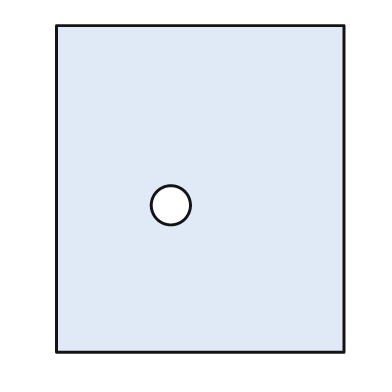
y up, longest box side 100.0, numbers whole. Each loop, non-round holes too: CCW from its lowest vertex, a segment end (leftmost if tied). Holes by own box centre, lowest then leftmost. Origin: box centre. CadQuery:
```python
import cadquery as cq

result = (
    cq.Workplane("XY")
    .moveTo(-44.0, -50.0)
    .lineTo(44.0, -50.0)
    .lineTo(44.0, 50.0)
    .lineTo(-44.0, 50.0)
    .close()
    .moveTo(-9.0, -5.0)
    .circle(6.0)
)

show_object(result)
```